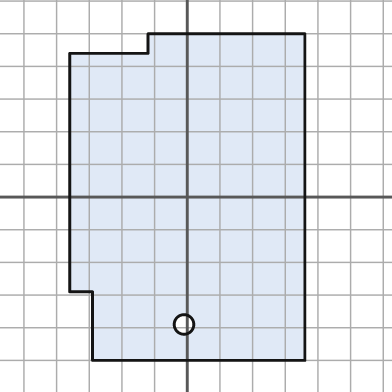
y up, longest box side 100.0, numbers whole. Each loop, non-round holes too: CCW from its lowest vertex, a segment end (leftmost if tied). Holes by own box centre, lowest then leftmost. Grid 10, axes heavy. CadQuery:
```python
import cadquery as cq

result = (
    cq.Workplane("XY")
    .moveTo(-29.0, -50.0)
    .lineTo(36.0, -50.0)
    .lineTo(36.0, 50.0)
    .lineTo(-12.0, 50.0)
    .lineTo(-12.0, 44.0)
    .lineTo(-36.0, 44.0)
    .lineTo(-36.0, -29.0)
    .lineTo(-29.0, -29.0)
    .close()
    .moveTo(-1.0, -39.0)
    .circle(3.0)
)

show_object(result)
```